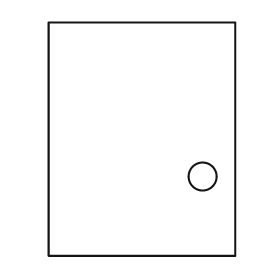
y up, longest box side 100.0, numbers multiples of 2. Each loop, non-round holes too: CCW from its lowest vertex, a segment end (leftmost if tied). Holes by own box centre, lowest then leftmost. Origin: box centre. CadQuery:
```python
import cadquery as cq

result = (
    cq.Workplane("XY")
    .moveTo(-40.0, -50.0)
    .lineTo(40.0, -50.0)
    .lineTo(40.0, 50.0)
    .lineTo(-40.0, 50.0)
    .close()
    .moveTo(26.0, -16.0)
    .circle(6.0)
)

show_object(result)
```